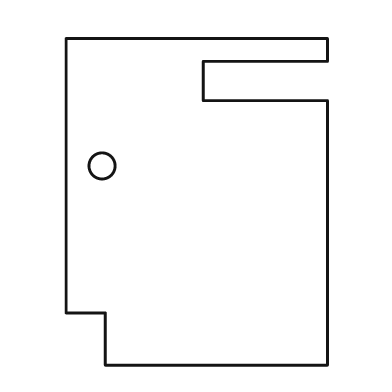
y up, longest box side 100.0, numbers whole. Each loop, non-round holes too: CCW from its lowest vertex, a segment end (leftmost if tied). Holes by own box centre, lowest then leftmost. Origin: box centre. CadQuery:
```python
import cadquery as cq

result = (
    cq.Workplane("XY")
    .moveTo(-28.0, -50.0)
    .lineTo(40.0, -50.0)
    .lineTo(40.0, 31.0)
    .lineTo(2.0, 31.0)
    .lineTo(2.0, 43.0)
    .lineTo(40.0, 43.0)
    .lineTo(40.0, 50.0)
    .lineTo(-40.0, 50.0)
    .lineTo(-40.0, -34.0)
    .lineTo(-28.0, -34.0)
    .close()
    .moveTo(-29.0, 11.0)
    .circle(4.0)
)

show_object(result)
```